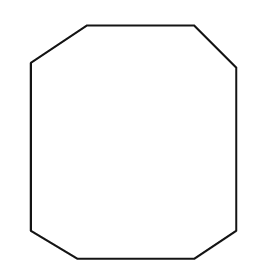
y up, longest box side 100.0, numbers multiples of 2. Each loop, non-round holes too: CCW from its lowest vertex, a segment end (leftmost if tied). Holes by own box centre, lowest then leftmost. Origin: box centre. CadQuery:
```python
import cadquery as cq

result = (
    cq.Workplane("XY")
    .moveTo(-24.0, -50.0)
    .lineTo(26.0, -50.0)
    .lineTo(44.0, -38.0)
    .lineTo(44.0, 32.0)
    .lineTo(26.0, 50.0)
    .lineTo(-20.0, 50.0)
    .lineTo(-44.0, 34.0)
    .lineTo(-44.0, -38.0)
    .close()
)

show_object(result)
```